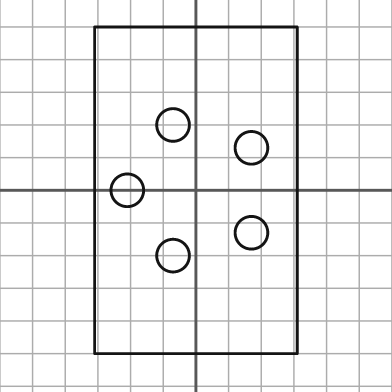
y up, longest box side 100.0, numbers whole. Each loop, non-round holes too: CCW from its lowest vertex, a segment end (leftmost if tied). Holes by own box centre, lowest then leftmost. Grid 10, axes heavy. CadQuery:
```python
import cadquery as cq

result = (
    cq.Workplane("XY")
    .moveTo(-31.0, -50.0)
    .lineTo(31.0, -50.0)
    .lineTo(31.0, 50.0)
    .lineTo(-31.0, 50.0)
    .close()
    .moveTo(-7.0, -20.0)
    .circle(5.0)
    .moveTo(17.0, -13.0)
    .circle(5.0)
    .moveTo(-21.0, 0.0)
    .circle(5.0)
    .moveTo(17.0, 13.0)
    .circle(5.0)
    .moveTo(-7.0, 20.0)
    .circle(5.0)
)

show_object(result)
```